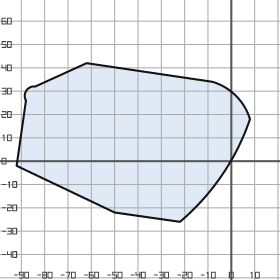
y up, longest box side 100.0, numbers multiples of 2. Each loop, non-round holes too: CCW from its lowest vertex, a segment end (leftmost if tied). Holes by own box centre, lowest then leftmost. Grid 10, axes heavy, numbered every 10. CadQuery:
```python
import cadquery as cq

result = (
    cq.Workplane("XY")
    .moveTo(-22.0, -26.0)
    .threePointArc((-4.0, -6.0), (8.0, 18.0))
    .threePointArc((2.0, 28.0), (-8.0, 34.0))
    .lineTo(-62.0, 42.0)
    .lineTo(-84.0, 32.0)
    .threePointArc((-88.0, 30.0), (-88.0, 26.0))
    .lineTo(-92.0, -2.0)
    .lineTo(-50.0, -22.0)
    .close()
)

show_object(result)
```